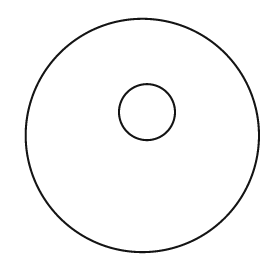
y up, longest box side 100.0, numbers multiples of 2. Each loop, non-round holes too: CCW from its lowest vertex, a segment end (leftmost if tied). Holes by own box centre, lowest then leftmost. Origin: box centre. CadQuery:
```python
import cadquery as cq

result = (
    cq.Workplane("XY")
    .moveTo(0.0, 0.0)
    .circle(50.0)
    .moveTo(2.0, 10.0)
    .circle(12.0)
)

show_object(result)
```